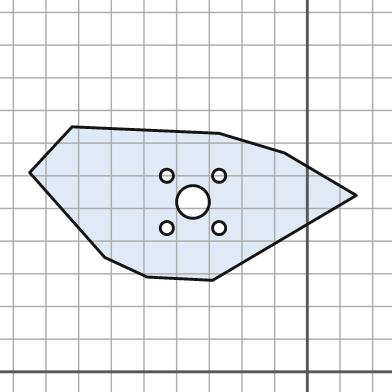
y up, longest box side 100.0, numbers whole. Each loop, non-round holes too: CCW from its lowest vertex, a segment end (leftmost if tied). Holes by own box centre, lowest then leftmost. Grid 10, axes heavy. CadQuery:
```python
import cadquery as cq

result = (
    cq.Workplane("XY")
    .moveTo(-29.0, 28.0)
    .lineTo(15.0, 54.0)
    .lineTo(-7.0, 67.0)
    .lineTo(-27.0, 73.0)
    .lineTo(-72.0, 75.0)
    .lineTo(-85.0, 61.0)
    .lineTo(-62.0, 35.0)
    .lineTo(-49.0, 29.0)
    .close()
    .moveTo(-43.0, 44.0)
    .circle(2.0)
    .moveTo(-27.0, 44.0)
    .circle(2.0)
    .moveTo(-35.0, 52.0)
    .circle(5.0)
    .moveTo(-43.0, 60.0)
    .circle(2.0)
    .moveTo(-27.0, 60.0)
    .circle(2.0)
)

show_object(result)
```